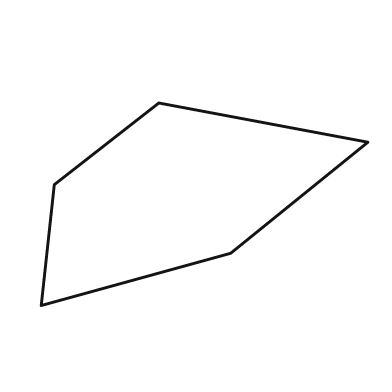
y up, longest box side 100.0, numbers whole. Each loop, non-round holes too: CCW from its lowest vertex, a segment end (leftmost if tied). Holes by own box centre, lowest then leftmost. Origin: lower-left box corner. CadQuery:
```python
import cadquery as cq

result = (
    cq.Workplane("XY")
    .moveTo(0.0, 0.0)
    .lineTo(58.0, 16.0)
    .lineTo(100.0, 50.0)
    .lineTo(36.0, 62.0)
    .lineTo(4.0, 37.0)
    .close()
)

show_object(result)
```